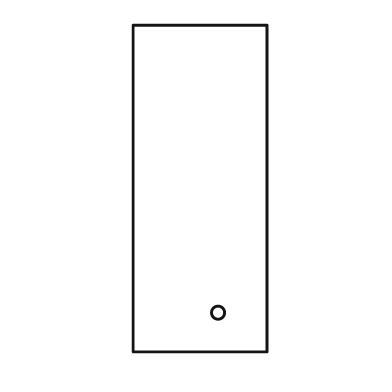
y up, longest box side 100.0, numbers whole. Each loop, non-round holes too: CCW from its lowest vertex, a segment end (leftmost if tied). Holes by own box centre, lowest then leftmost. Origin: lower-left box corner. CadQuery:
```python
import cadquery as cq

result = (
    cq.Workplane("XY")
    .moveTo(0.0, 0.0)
    .lineTo(41.0, 0.0)
    .lineTo(41.0, 100.0)
    .lineTo(0.0, 100.0)
    .close()
    .moveTo(26.0, 12.0)
    .circle(2.0)
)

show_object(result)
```